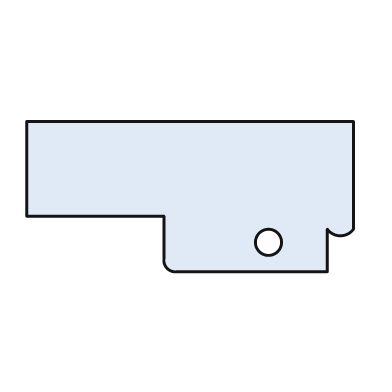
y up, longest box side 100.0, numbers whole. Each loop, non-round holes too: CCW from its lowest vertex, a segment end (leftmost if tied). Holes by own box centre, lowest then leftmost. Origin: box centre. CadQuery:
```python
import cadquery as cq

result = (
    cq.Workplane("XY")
    .moveTo(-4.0, -23.0)
    .lineTo(42.0, -23.0)
    .lineTo(42.0, -10.0)
    .threePointArc((46.0, -12.0), (50.0, -10.0))
    .lineTo(50.0, 23.0)
    .lineTo(-50.0, 23.0)
    .lineTo(-50.0, -6.0)
    .lineTo(-8.0, -6.0)
    .lineTo(-8.0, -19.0)
    .threePointArc((-7.0, -22.0), (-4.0, -23.0))
    .close()
    .moveTo(24.0, -14.0)
    .circle(4.0)
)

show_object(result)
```